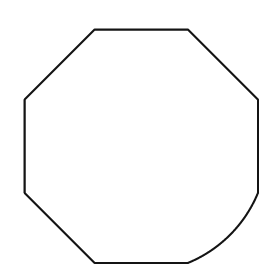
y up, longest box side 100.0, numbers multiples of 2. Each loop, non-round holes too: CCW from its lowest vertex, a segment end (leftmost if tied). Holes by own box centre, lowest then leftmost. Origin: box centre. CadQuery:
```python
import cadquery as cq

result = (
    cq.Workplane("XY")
    .moveTo(-20.0, -50.0)
    .lineTo(20.0, -50.0)
    .threePointArc((38.0, -38.0), (50.0, -20.0))
    .lineTo(50.0, 20.0)
    .lineTo(20.0, 50.0)
    .lineTo(-20.0, 50.0)
    .lineTo(-50.0, 20.0)
    .lineTo(-50.0, -20.0)
    .close()
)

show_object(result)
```